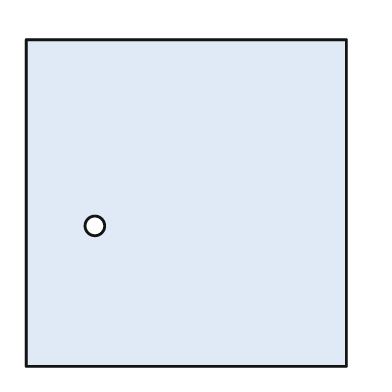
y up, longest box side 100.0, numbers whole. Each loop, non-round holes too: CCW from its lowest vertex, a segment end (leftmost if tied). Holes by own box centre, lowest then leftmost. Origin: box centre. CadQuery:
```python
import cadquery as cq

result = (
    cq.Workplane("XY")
    .moveTo(-49.0, -50.0)
    .lineTo(49.0, -50.0)
    .lineTo(49.0, 50.0)
    .lineTo(-49.0, 50.0)
    .close()
    .moveTo(-28.0, -7.0)
    .circle(3.0)
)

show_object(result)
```